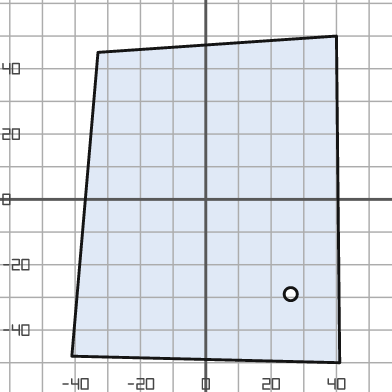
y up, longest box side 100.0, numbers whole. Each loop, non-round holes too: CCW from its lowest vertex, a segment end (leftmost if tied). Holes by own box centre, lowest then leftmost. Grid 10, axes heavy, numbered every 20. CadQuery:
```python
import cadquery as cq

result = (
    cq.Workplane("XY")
    .moveTo(41.0, -50.0)
    .lineTo(40.0, 50.0)
    .lineTo(-33.0, 45.0)
    .lineTo(-41.0, -48.0)
    .close()
    .moveTo(26.0, -29.0)
    .circle(2.0)
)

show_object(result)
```